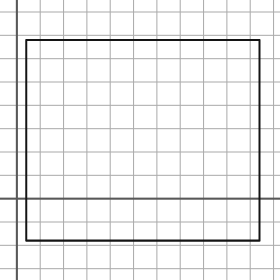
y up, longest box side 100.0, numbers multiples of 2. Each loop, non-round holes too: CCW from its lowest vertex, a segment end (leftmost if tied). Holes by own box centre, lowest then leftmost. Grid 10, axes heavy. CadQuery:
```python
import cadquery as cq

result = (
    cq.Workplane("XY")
    .moveTo(4.0, -18.0)
    .lineTo(104.0, -18.0)
    .lineTo(104.0, 68.0)
    .lineTo(4.0, 68.0)
    .close()
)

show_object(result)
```